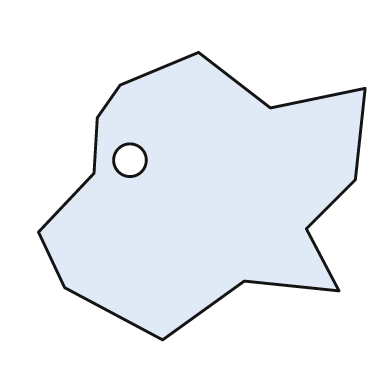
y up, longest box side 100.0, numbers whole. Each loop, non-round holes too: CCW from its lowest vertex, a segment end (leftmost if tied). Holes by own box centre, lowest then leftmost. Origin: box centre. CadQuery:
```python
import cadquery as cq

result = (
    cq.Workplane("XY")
    .moveTo(-12.0, -44.0)
    .lineTo(13.0, -26.0)
    .lineTo(42.0, -29.0)
    .lineTo(32.0, -10.0)
    .lineTo(47.0, 5.0)
    .lineTo(50.0, 33.0)
    .lineTo(21.0, 27.0)
    .lineTo(-1.0, 44.0)
    .lineTo(-25.0, 34.0)
    .lineTo(-32.0, 24.0)
    .lineTo(-33.0, 7.0)
    .lineTo(-50.0, -11.0)
    .lineTo(-42.0, -28.0)
    .close()
    .moveTo(-22.0, 11.0)
    .circle(5.0)
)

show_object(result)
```